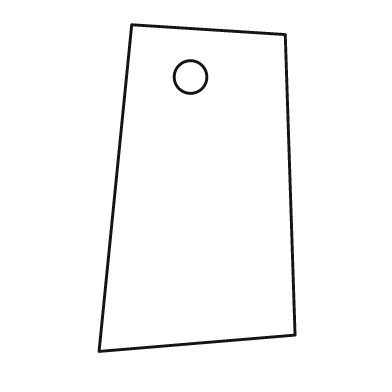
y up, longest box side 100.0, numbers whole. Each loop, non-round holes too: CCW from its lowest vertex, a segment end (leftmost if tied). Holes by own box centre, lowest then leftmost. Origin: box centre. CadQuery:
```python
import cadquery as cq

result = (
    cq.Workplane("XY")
    .moveTo(-30.0, -50.0)
    .lineTo(30.0, -45.0)
    .lineTo(27.0, 47.0)
    .lineTo(-20.0, 50.0)
    .close()
    .moveTo(-2.0, 34.0)
    .circle(5.0)
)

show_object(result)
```